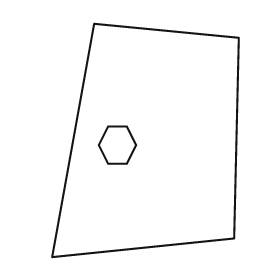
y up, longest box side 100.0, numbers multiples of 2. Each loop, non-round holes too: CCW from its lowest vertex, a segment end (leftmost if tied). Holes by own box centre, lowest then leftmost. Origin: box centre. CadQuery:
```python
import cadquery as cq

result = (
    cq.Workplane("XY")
    .moveTo(-40.0, -50.0)
    .lineTo(38.0, -42.0)
    .lineTo(40.0, 44.0)
    .lineTo(-22.0, 50.0)
    .close()
    .moveTo(-16.0, -10.0)
    .lineTo(-8.0, -10.0)
    .lineTo(-4.0, -2.0)
    .lineTo(-8.0, 6.0)
    .lineTo(-16.0, 6.0)
    .lineTo(-20.0, -2.0)
    .close()
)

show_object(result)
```